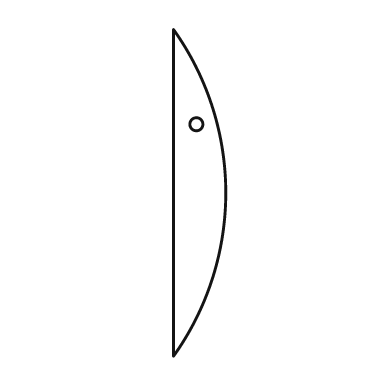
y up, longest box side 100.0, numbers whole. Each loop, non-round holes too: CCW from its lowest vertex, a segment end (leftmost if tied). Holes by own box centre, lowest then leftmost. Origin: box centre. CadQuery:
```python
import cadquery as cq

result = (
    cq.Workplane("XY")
    .moveTo(-8.0, -50.0)
    .threePointArc((8.0, 0.0), (-8.0, 50.0))
    .close()
    .moveTo(-1.0, 21.0)
    .circle(2.0)
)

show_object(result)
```